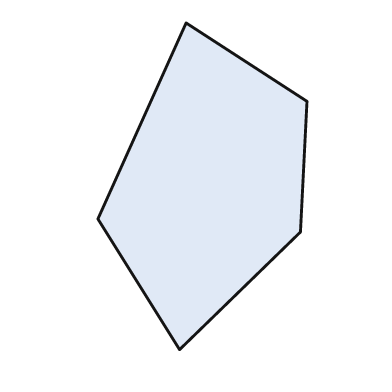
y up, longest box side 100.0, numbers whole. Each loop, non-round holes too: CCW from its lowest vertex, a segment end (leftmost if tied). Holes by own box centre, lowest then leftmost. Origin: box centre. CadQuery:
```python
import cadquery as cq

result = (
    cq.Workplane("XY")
    .moveTo(-7.0, -50.0)
    .lineTo(30.0, -14.0)
    .lineTo(32.0, 26.0)
    .lineTo(-5.0, 50.0)
    .lineTo(-32.0, -10.0)
    .close()
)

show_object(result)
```